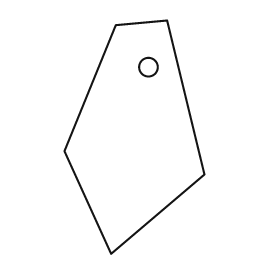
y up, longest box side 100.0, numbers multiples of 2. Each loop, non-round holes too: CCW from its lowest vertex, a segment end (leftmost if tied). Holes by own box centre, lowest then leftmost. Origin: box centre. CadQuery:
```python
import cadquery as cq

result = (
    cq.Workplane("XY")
    .moveTo(-10.0, -50.0)
    .lineTo(30.0, -16.0)
    .lineTo(14.0, 50.0)
    .lineTo(-8.0, 48.0)
    .lineTo(-30.0, -6.0)
    .close()
    .moveTo(6.0, 30.0)
    .circle(4.0)
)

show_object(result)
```